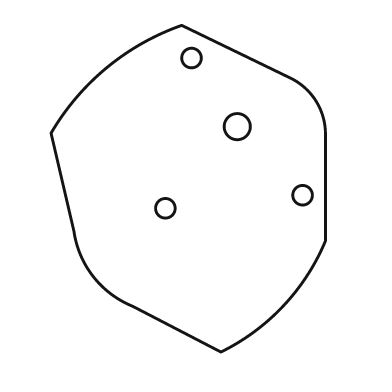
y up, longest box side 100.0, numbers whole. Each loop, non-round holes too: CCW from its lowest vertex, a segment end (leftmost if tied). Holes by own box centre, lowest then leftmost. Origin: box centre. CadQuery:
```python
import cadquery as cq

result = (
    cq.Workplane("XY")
    .moveTo(10.0, -50.0)
    .threePointArc((29.0, -36.0), (42.0, -16.0))
    .lineTo(42.0, 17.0)
    .threePointArc((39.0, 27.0), (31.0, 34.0))
    .lineTo(-2.0, 50.0)
    .threePointArc((-25.0, 37.0), (-42.0, 17.0))
    .lineTo(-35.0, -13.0)
    .threePointArc((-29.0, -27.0), (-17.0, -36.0))
    .close()
    .moveTo(-7.0, -6.0)
    .circle(3.0)
    .moveTo(35.0, -2.0)
    .circle(3.0)
    .moveTo(15.0, 19.0)
    .circle(4.0)
    .moveTo(1.0, 40.0)
    .circle(3.0)
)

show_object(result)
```